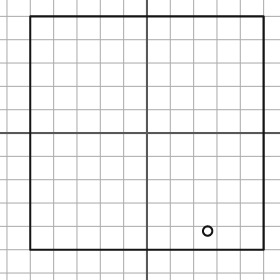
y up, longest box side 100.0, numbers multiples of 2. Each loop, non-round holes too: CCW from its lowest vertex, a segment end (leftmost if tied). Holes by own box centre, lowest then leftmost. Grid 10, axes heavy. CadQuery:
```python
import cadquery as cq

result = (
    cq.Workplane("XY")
    .moveTo(-50.0, -50.0)
    .lineTo(50.0, -50.0)
    .lineTo(50.0, 50.0)
    .lineTo(-50.0, 50.0)
    .close()
    .moveTo(26.0, -42.0)
    .circle(2.0)
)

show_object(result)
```